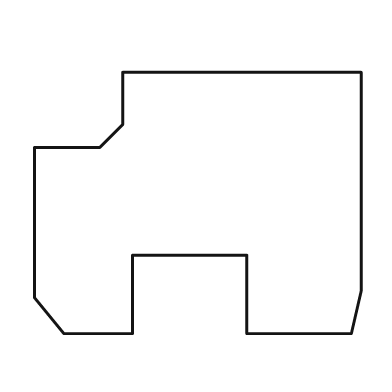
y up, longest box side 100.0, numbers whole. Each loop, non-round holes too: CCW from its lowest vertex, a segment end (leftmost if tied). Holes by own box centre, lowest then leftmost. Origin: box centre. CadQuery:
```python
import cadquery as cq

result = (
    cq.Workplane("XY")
    .moveTo(-41.0, -40.0)
    .lineTo(-20.0, -40.0)
    .lineTo(-20.0, -16.0)
    .lineTo(15.0, -16.0)
    .lineTo(15.0, -40.0)
    .lineTo(47.0, -40.0)
    .lineTo(50.0, -27.0)
    .lineTo(50.0, 40.0)
    .lineTo(-23.0, 40.0)
    .lineTo(-23.0, 24.0)
    .lineTo(-30.0, 17.0)
    .lineTo(-50.0, 17.0)
    .lineTo(-50.0, -29.0)
    .close()
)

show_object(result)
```